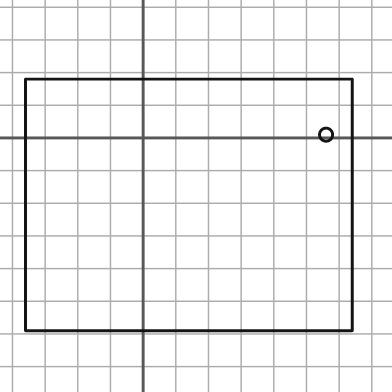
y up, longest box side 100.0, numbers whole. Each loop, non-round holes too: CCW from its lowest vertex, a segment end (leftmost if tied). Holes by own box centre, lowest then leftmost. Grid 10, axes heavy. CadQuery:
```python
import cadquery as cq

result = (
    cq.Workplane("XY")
    .moveTo(-36.0, -59.0)
    .lineTo(64.0, -59.0)
    .lineTo(64.0, 18.0)
    .lineTo(-36.0, 18.0)
    .close()
    .moveTo(56.0, 1.0)
    .circle(2.0)
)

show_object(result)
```